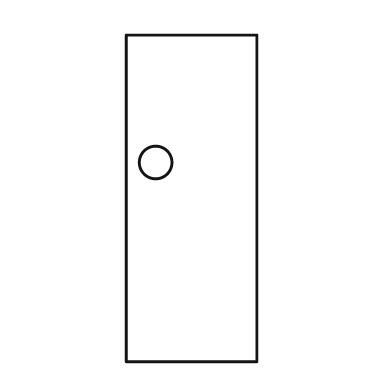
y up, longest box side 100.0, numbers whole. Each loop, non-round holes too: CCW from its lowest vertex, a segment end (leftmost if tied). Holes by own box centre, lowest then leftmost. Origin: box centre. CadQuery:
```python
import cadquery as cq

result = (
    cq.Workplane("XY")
    .moveTo(-20.0, -50.0)
    .lineTo(20.0, -50.0)
    .lineTo(20.0, 50.0)
    .lineTo(-20.0, 50.0)
    .close()
    .moveTo(-11.0, 11.0)
    .circle(5.0)
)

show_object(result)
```